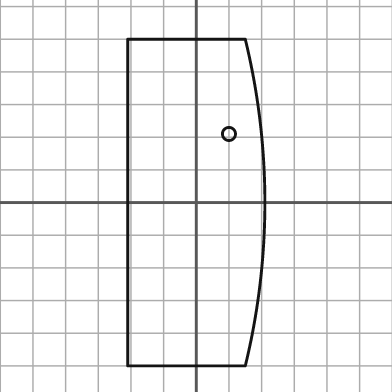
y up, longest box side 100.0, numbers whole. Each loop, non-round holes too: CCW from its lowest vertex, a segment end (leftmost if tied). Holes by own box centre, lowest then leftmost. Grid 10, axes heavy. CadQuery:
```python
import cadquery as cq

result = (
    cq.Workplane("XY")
    .moveTo(-21.0, -50.0)
    .lineTo(15.0, -50.0)
    .threePointArc((21.0, 0.0), (15.0, 50.0))
    .lineTo(-21.0, 50.0)
    .close()
    .moveTo(10.0, 21.0)
    .circle(2.0)
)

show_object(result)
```